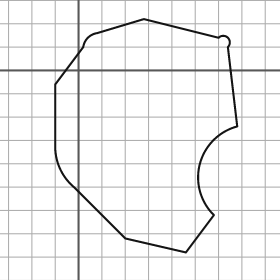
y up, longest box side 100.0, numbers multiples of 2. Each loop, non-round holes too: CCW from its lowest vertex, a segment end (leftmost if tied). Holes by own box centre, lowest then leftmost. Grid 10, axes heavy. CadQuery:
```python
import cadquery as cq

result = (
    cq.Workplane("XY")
    .moveTo(46.0, -78.0)
    .lineTo(58.0, -62.0)
    .threePointArc((52.0, -40.0), (68.0, -24.0))
    .lineTo(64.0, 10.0)
    .threePointArc((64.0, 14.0), (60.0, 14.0))
    .lineTo(28.0, 22.0)
    .lineTo(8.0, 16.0)
    .threePointArc((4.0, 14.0), (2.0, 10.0))
    .lineTo(-10.0, -6.0)
    .lineTo(-10.0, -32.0)
    .threePointArc((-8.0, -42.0), (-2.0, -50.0))
    .lineTo(20.0, -72.0)
    .close()
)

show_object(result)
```